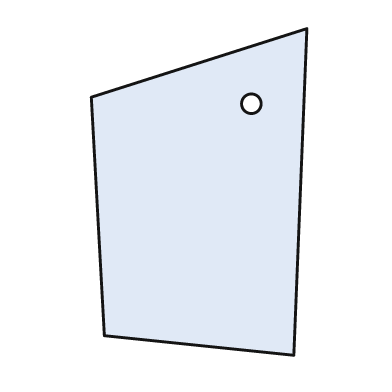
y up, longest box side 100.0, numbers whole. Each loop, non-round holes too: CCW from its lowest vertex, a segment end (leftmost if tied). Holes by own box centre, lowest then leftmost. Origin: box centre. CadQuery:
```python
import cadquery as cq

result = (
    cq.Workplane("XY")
    .moveTo(29.0, -50.0)
    .lineTo(33.0, 50.0)
    .lineTo(-33.0, 29.0)
    .lineTo(-29.0, -44.0)
    .close()
    .moveTo(16.0, 27.0)
    .circle(3.0)
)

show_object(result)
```